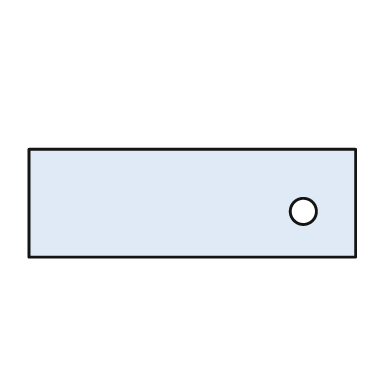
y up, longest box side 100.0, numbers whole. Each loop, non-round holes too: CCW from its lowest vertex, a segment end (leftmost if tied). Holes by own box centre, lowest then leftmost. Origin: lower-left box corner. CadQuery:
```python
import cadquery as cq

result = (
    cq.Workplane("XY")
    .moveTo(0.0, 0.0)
    .lineTo(100.0, 0.0)
    .lineTo(100.0, 33.0)
    .lineTo(0.0, 33.0)
    .close()
    .moveTo(84.0, 14.0)
    .circle(4.0)
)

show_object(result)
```